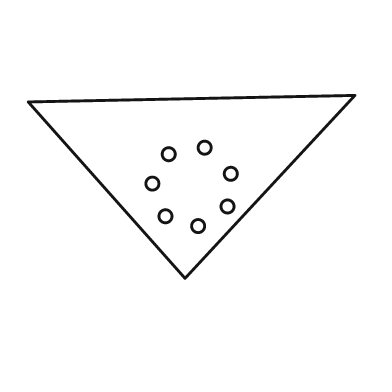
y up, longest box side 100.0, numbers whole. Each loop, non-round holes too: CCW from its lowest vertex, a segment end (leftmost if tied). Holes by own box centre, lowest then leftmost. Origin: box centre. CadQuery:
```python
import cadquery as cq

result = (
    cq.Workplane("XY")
    .moveTo(-2.0, -28.0)
    .lineTo(50.0, 28.0)
    .lineTo(-50.0, 26.0)
    .close()
    .moveTo(2.0, -12.0)
    .circle(2.0)
    .moveTo(-8.0, -9.0)
    .circle(2.0)
    .moveTo(11.0, -6.0)
    .circle(2.0)
    .moveTo(-12.0, 1.0)
    .circle(2.0)
    .moveTo(12.0, 4.0)
    .circle(2.0)
    .moveTo(-7.0, 10.0)
    .circle(2.0)
    .moveTo(4.0, 12.0)
    .circle(2.0)
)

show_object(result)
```